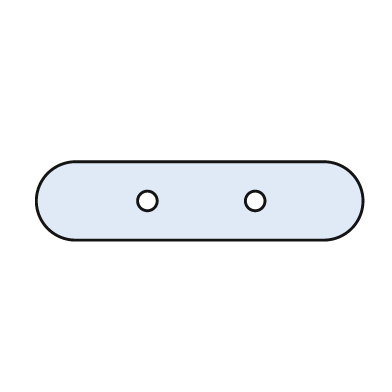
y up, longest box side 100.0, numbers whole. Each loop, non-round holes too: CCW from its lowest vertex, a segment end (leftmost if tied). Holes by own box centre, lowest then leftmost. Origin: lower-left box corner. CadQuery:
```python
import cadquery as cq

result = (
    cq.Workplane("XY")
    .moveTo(12.0, 0.0)
    .lineTo(88.0, 0.0)
    .threePointArc((100.0, 12.0), (88.0, 24.0))
    .lineTo(12.0, 24.0)
    .threePointArc((0.0, 12.0), (12.0, 0.0))
    .close()
    .moveTo(34.0, 12.0)
    .circle(3.0)
    .moveTo(67.0, 12.0)
    .circle(3.0)
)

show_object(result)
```